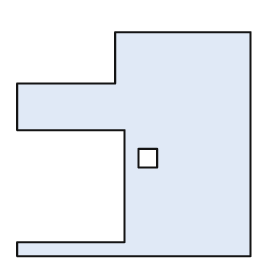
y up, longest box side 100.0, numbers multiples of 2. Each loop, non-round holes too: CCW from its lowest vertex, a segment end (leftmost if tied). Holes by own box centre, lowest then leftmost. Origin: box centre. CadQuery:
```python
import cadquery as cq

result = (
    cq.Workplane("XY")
    .moveTo(-50.0, -48.0)
    .lineTo(50.0, -48.0)
    .lineTo(50.0, 48.0)
    .lineTo(-8.0, 48.0)
    .lineTo(-8.0, 26.0)
    .lineTo(-50.0, 26.0)
    .lineTo(-50.0, 6.0)
    .lineTo(-4.0, 6.0)
    .lineTo(-4.0, -42.0)
    .lineTo(-50.0, -42.0)
    .close()
    .moveTo(2.0, -10.0)
    .lineTo(10.0, -10.0)
    .lineTo(10.0, -2.0)
    .lineTo(2.0, -2.0)
    .close()
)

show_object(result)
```